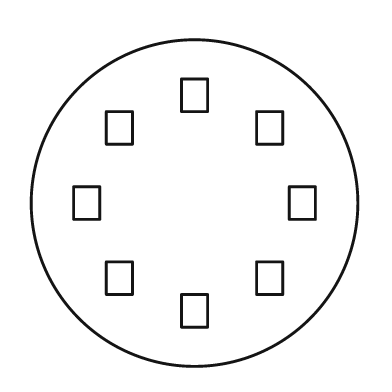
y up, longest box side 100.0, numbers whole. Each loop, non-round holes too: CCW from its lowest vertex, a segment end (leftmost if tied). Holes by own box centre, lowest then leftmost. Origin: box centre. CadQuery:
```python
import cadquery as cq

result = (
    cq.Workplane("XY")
    .moveTo(0.0, 0.0)
    .circle(50.0)
    .moveTo(-4.0, -38.0)
    .lineTo(4.0, -38.0)
    .lineTo(4.0, -28.0)
    .lineTo(-4.0, -28.0)
    .close()
    .moveTo(-27.0, -28.0)
    .lineTo(-19.0, -28.0)
    .lineTo(-19.0, -18.0)
    .lineTo(-27.0, -18.0)
    .close()
    .moveTo(19.0, -28.0)
    .lineTo(27.0, -28.0)
    .lineTo(27.0, -18.0)
    .lineTo(19.0, -18.0)
    .close()
    .moveTo(-37.0, -5.0)
    .lineTo(-29.0, -5.0)
    .lineTo(-29.0, 5.0)
    .lineTo(-37.0, 5.0)
    .close()
    .moveTo(29.0, -5.0)
    .lineTo(37.0, -5.0)
    .lineTo(37.0, 5.0)
    .lineTo(29.0, 5.0)
    .close()
    .moveTo(-27.0, 18.0)
    .lineTo(-19.0, 18.0)
    .lineTo(-19.0, 28.0)
    .lineTo(-27.0, 28.0)
    .close()
    .moveTo(19.0, 18.0)
    .lineTo(27.0, 18.0)
    .lineTo(27.0, 28.0)
    .lineTo(19.0, 28.0)
    .close()
    .moveTo(-4.0, 28.0)
    .lineTo(4.0, 28.0)
    .lineTo(4.0, 38.0)
    .lineTo(-4.0, 38.0)
    .close()
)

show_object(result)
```